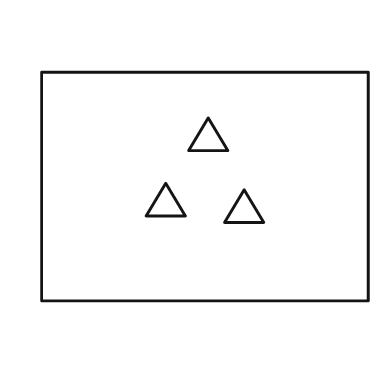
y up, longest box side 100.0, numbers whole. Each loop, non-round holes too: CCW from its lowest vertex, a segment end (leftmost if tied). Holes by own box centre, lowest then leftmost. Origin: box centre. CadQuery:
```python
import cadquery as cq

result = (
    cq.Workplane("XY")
    .moveTo(-50.0, -35.0)
    .lineTo(50.0, -35.0)
    .lineTo(50.0, 35.0)
    .lineTo(-50.0, 35.0)
    .close()
    .moveTo(6.0, -11.0)
    .lineTo(18.0, -11.0)
    .lineTo(12.0, -1.0)
    .close()
    .moveTo(-18.0, -9.0)
    .lineTo(-6.0, -9.0)
    .lineTo(-12.0, 1.0)
    .close()
    .moveTo(-5.0, 11.0)
    .lineTo(7.0, 11.0)
    .lineTo(1.0, 21.0)
    .close()
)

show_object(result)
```